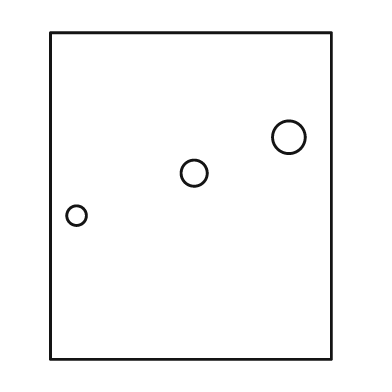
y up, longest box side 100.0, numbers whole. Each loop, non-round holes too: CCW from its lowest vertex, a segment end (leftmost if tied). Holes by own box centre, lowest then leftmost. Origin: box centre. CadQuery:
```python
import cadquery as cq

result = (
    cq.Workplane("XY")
    .moveTo(-43.0, -50.0)
    .lineTo(43.0, -50.0)
    .lineTo(43.0, 50.0)
    .lineTo(-43.0, 50.0)
    .close()
    .moveTo(-35.0, -6.0)
    .circle(3.0)
    .moveTo(1.0, 7.0)
    .circle(4.0)
    .moveTo(30.0, 18.0)
    .circle(5.0)
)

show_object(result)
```